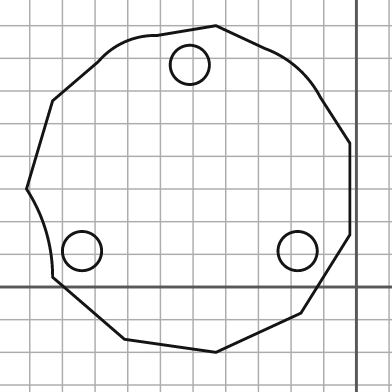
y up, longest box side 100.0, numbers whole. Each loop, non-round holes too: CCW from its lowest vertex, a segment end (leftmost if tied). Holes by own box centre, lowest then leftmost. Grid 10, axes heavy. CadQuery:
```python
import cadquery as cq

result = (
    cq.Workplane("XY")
    .moveTo(-43.0, -20.0)
    .lineTo(-17.0, -8.0)
    .lineTo(-2.0, 16.0)
    .lineTo(-2.0, 44.0)
    .lineTo(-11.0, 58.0)
    .threePointArc((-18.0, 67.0), (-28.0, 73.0))
    .lineTo(-43.0, 80.0)
    .lineTo(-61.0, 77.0)
    .threePointArc((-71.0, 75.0), (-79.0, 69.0))
    .lineTo(-93.0, 57.0)
    .lineTo(-101.0, 30.0)
    .threePointArc((-95.0, 17.0), (-93.0, 3.0))
    .lineTo(-71.0, -16.0)
    .close()
    .moveTo(-84.0, 11.0)
    .circle(6.0)
    .moveTo(-18.0, 11.0)
    .circle(6.0)
    .moveTo(-51.0, 68.0)
    .circle(6.0)
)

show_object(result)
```